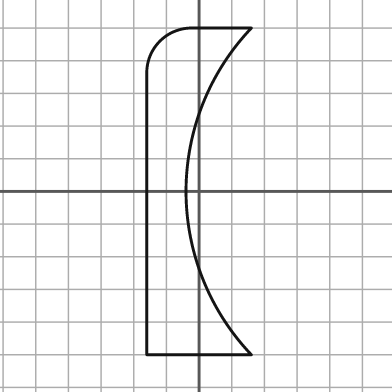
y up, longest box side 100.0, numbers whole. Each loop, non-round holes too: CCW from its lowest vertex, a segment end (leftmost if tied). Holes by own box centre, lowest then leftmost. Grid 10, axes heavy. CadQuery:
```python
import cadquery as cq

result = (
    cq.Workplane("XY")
    .moveTo(-16.0, -50.0)
    .lineTo(16.0, -50.0)
    .threePointArc((-4.0, 0.0), (16.0, 50.0))
    .lineTo(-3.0, 50.0)
    .threePointArc((-12.0, 46.0), (-16.0, 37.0))
    .close()
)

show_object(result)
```